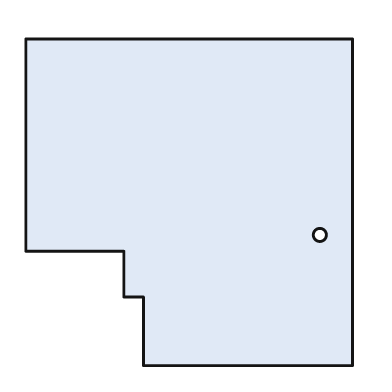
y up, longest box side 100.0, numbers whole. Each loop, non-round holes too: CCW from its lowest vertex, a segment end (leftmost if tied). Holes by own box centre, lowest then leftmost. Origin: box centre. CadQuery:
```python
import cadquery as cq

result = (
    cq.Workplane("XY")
    .moveTo(-14.0, -50.0)
    .lineTo(50.0, -50.0)
    .lineTo(50.0, 50.0)
    .lineTo(-50.0, 50.0)
    .lineTo(-50.0, -15.0)
    .lineTo(-20.0, -15.0)
    .lineTo(-20.0, -29.0)
    .lineTo(-14.0, -29.0)
    .close()
    .moveTo(40.0, -10.0)
    .circle(2.0)
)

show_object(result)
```